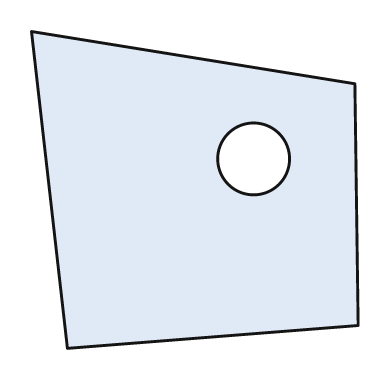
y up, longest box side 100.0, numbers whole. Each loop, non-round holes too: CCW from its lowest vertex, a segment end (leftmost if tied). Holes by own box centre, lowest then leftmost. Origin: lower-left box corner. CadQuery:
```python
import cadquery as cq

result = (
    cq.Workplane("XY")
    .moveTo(11.0, 0.0)
    .lineTo(100.0, 7.0)
    .lineTo(99.0, 81.0)
    .lineTo(0.0, 97.0)
    .close()
    .moveTo(68.0, 58.0)
    .circle(11.0)
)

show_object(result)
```